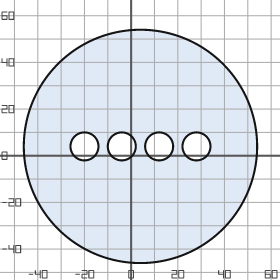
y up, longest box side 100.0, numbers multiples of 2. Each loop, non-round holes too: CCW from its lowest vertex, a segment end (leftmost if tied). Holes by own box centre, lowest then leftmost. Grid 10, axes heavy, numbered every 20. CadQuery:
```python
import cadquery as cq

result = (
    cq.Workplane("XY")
    .moveTo(4.0, 4.0)
    .circle(50.0)
    .moveTo(-20.0, 4.0)
    .circle(6.0)
    .moveTo(-4.0, 4.0)
    .circle(6.0)
    .moveTo(12.0, 4.0)
    .circle(6.0)
    .moveTo(28.0, 4.0)
    .circle(6.0)
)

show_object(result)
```